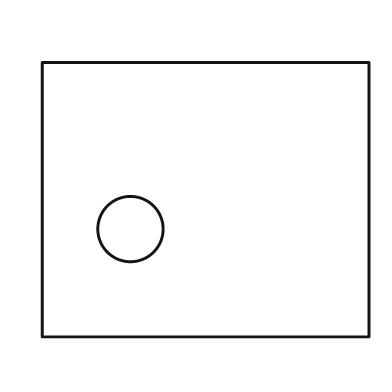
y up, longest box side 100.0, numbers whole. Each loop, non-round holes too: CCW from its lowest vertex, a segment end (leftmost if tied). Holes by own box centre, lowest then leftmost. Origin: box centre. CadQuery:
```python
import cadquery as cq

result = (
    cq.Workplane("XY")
    .moveTo(-50.0, -42.0)
    .lineTo(50.0, -42.0)
    .lineTo(50.0, 42.0)
    .lineTo(-50.0, 42.0)
    .close()
    .moveTo(-23.0, -9.0)
    .circle(10.0)
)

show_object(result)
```